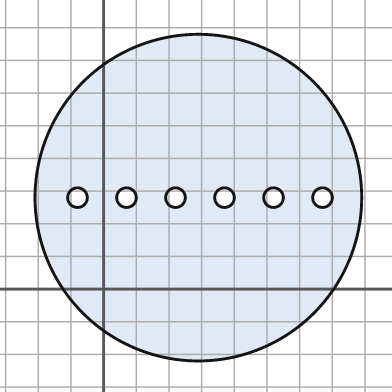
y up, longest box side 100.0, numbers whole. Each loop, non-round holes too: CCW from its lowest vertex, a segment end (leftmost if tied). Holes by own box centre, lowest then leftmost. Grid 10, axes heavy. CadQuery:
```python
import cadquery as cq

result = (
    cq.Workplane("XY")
    .moveTo(29.0, 28.0)
    .circle(50.0)
    .moveTo(-8.0, 28.0)
    .circle(3.0)
    .moveTo(7.0, 28.0)
    .circle(3.0)
    .moveTo(22.0, 28.0)
    .circle(3.0)
    .moveTo(37.0, 28.0)
    .circle(3.0)
    .moveTo(52.0, 28.0)
    .circle(3.0)
    .moveTo(67.0, 28.0)
    .circle(3.0)
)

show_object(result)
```